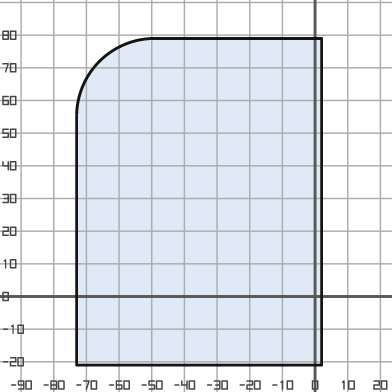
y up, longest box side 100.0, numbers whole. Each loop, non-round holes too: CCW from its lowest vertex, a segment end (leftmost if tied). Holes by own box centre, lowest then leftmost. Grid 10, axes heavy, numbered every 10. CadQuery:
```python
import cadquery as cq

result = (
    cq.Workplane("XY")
    .moveTo(-73.0, -21.0)
    .lineTo(2.0, -21.0)
    .lineTo(2.0, 79.0)
    .lineTo(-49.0, 79.0)
    .threePointArc((-66.0, 72.0), (-73.0, 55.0))
    .close()
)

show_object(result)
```